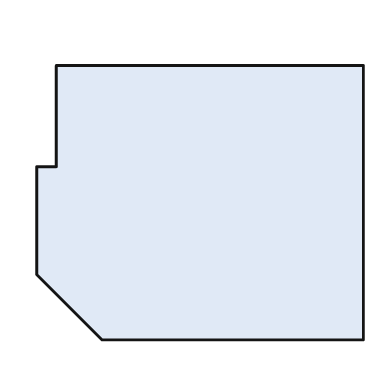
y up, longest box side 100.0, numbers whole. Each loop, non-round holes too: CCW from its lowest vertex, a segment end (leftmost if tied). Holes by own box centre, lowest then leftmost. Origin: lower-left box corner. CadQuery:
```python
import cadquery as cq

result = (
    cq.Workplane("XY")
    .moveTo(20.0, 0.0)
    .lineTo(100.0, 0.0)
    .lineTo(100.0, 84.0)
    .lineTo(6.0, 84.0)
    .lineTo(6.0, 53.0)
    .lineTo(0.0, 53.0)
    .lineTo(0.0, 20.0)
    .close()
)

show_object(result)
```